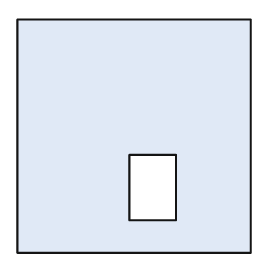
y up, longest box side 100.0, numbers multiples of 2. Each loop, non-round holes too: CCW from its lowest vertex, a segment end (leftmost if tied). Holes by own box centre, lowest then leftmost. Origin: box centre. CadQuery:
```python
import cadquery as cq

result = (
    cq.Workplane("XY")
    .moveTo(-50.0, -50.0)
    .lineTo(50.0, -50.0)
    .lineTo(50.0, 50.0)
    .lineTo(-50.0, 50.0)
    .close()
    .moveTo(-2.0, -36.0)
    .lineTo(18.0, -36.0)
    .lineTo(18.0, -8.0)
    .lineTo(-2.0, -8.0)
    .close()
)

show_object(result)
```